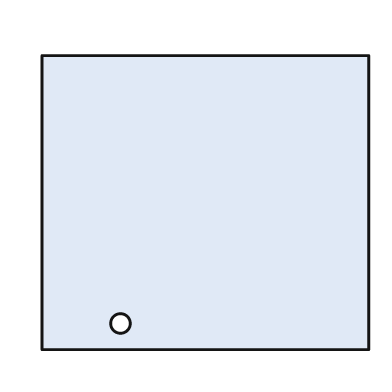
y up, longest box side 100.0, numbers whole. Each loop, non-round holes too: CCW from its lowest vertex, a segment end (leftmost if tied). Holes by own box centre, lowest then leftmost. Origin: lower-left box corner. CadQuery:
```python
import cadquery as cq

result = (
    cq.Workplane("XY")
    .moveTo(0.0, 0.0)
    .lineTo(100.0, 0.0)
    .lineTo(100.0, 90.0)
    .lineTo(0.0, 90.0)
    .close()
    .moveTo(24.0, 8.0)
    .circle(3.0)
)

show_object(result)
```